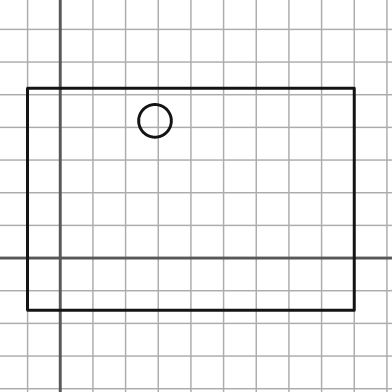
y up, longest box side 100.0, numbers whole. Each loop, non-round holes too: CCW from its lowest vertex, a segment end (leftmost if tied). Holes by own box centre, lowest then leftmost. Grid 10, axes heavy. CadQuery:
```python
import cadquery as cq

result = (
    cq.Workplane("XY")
    .moveTo(-10.0, -16.0)
    .lineTo(90.0, -16.0)
    .lineTo(90.0, 52.0)
    .lineTo(-10.0, 52.0)
    .close()
    .moveTo(29.0, 42.0)
    .circle(5.0)
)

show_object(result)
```